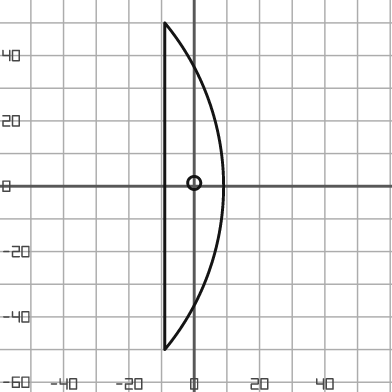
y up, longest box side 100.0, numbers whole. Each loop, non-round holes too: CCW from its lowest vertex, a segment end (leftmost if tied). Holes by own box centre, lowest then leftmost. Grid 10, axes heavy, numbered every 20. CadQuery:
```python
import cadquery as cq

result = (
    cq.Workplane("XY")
    .moveTo(-9.0, -50.0)
    .threePointArc((9.0, 0.0), (-9.0, 50.0))
    .close()
    .moveTo(0.0, 1.0)
    .circle(2.0)
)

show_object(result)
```